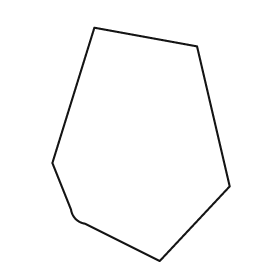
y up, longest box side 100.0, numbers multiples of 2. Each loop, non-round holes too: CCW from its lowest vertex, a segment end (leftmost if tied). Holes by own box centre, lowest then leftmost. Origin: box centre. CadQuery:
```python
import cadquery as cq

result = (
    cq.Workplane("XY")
    .moveTo(8.0, -50.0)
    .lineTo(38.0, -18.0)
    .lineTo(24.0, 42.0)
    .lineTo(-20.0, 50.0)
    .lineTo(-38.0, -8.0)
    .lineTo(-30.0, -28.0)
    .threePointArc((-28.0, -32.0), (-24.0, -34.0))
    .close()
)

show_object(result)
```